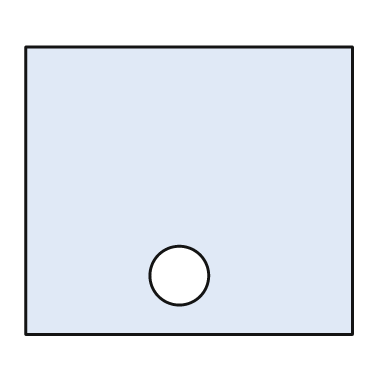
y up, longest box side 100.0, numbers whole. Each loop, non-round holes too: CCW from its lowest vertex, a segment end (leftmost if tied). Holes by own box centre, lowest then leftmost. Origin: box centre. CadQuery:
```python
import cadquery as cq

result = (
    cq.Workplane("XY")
    .moveTo(-50.0, -44.0)
    .lineTo(50.0, -44.0)
    .lineTo(50.0, 44.0)
    .lineTo(-50.0, 44.0)
    .close()
    .moveTo(-3.0, -26.0)
    .circle(9.0)
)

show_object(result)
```